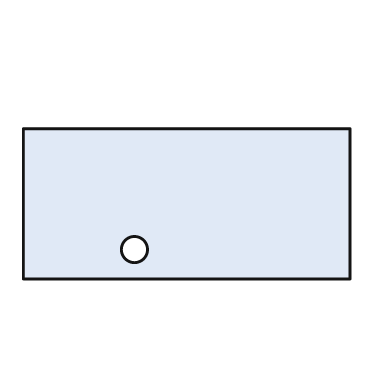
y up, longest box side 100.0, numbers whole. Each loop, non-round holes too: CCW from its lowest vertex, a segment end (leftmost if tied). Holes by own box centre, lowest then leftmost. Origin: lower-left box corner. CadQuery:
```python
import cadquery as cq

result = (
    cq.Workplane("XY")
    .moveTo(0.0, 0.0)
    .lineTo(100.0, 0.0)
    .lineTo(100.0, 46.0)
    .lineTo(0.0, 46.0)
    .close()
    .moveTo(34.0, 9.0)
    .circle(4.0)
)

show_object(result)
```